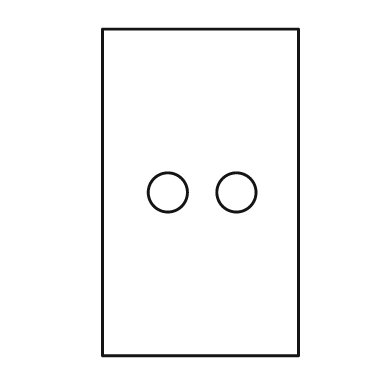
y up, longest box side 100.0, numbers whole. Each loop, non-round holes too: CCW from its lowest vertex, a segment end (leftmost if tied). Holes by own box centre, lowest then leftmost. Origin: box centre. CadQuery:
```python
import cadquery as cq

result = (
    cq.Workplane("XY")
    .moveTo(-30.0, -50.0)
    .lineTo(30.0, -50.0)
    .lineTo(30.0, 50.0)
    .lineTo(-30.0, 50.0)
    .close()
    .moveTo(-10.0, 0.0)
    .circle(6.0)
    .moveTo(11.0, 0.0)
    .circle(6.0)
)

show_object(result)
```